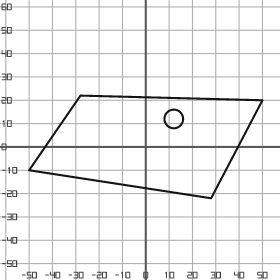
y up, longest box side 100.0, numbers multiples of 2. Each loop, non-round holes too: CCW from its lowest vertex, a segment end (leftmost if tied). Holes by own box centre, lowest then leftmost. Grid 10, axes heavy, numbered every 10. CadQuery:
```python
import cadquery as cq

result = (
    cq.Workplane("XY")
    .moveTo(28.0, -22.0)
    .lineTo(50.0, 20.0)
    .lineTo(-28.0, 22.0)
    .lineTo(-50.0, -10.0)
    .close()
    .moveTo(12.0, 12.0)
    .circle(4.0)
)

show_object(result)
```